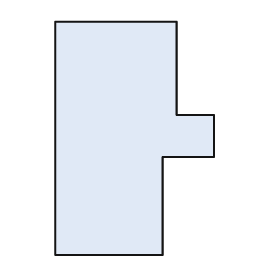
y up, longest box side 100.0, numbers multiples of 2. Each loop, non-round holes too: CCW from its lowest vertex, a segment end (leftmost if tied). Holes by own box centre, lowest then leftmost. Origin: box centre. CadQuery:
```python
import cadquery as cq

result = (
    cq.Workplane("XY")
    .moveTo(-34.0, -50.0)
    .lineTo(12.0, -50.0)
    .lineTo(12.0, -8.0)
    .lineTo(34.0, -8.0)
    .lineTo(34.0, 10.0)
    .lineTo(18.0, 10.0)
    .lineTo(18.0, 50.0)
    .lineTo(-34.0, 50.0)
    .close()
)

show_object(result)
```